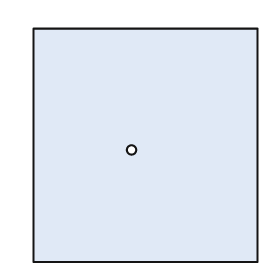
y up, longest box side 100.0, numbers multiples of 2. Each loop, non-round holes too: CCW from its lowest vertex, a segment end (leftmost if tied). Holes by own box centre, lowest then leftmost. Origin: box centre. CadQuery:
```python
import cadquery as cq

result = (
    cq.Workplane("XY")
    .moveTo(-48.0, -50.0)
    .lineTo(48.0, -50.0)
    .lineTo(48.0, 50.0)
    .lineTo(-48.0, 50.0)
    .close()
    .moveTo(-6.0, -2.0)
    .circle(2.0)
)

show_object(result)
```